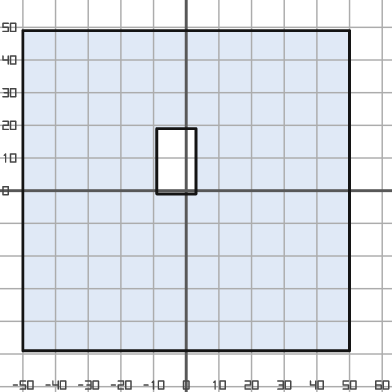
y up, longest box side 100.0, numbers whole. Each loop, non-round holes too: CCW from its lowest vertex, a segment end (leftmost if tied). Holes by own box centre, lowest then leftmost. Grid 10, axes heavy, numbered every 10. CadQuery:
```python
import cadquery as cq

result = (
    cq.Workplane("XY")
    .moveTo(-50.0, -49.0)
    .lineTo(50.0, -49.0)
    .lineTo(50.0, 49.0)
    .lineTo(-50.0, 49.0)
    .close()
    .moveTo(-9.0, -1.0)
    .lineTo(3.0, -1.0)
    .lineTo(3.0, 19.0)
    .lineTo(-9.0, 19.0)
    .close()
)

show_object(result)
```